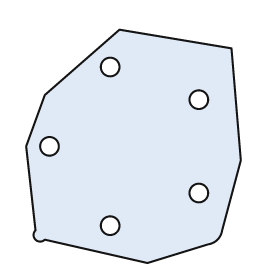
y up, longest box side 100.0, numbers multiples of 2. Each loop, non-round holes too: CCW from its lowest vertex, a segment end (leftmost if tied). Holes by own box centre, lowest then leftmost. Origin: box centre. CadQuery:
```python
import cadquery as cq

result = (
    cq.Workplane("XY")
    .moveTo(6.0, -50.0)
    .lineTo(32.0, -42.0)
    .threePointArc((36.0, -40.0), (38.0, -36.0))
    .lineTo(46.0, -6.0)
    .lineTo(42.0, 42.0)
    .lineTo(-6.0, 50.0)
    .lineTo(-38.0, 22.0)
    .lineTo(-46.0, 0.0)
    .lineTo(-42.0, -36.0)
    .threePointArc((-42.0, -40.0), (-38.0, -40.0))
    .close()
    .moveTo(-10.0, -34.0)
    .circle(4.0)
    .moveTo(28.0, -20.0)
    .circle(4.0)
    .moveTo(-36.0, 0.0)
    .circle(4.0)
    .moveTo(28.0, 20.0)
    .circle(4.0)
    .moveTo(-10.0, 34.0)
    .circle(4.0)
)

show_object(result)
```